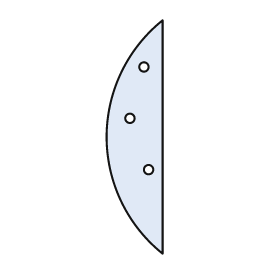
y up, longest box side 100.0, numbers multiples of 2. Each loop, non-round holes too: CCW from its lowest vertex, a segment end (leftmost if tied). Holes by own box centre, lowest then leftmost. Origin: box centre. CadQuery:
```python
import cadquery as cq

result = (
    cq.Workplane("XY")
    .moveTo(12.0, -50.0)
    .lineTo(12.0, 50.0)
    .threePointArc((-12.0, 0.0), (12.0, -50.0))
    .close()
    .moveTo(6.0, -14.0)
    .circle(2.0)
    .moveTo(-2.0, 8.0)
    .circle(2.0)
    .moveTo(4.0, 30.0)
    .circle(2.0)
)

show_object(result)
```